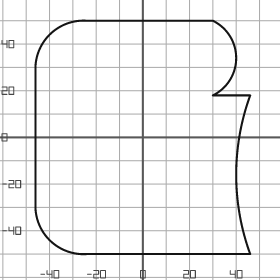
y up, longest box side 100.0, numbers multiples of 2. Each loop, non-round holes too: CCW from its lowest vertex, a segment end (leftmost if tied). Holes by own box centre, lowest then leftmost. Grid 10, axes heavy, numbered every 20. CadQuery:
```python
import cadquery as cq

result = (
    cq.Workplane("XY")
    .moveTo(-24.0, -50.0)
    .lineTo(46.0, -50.0)
    .threePointArc((40.0, -16.0), (46.0, 18.0))
    .lineTo(30.0, 18.0)
    .threePointArc((40.0, 34.0), (30.0, 50.0))
    .lineTo(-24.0, 50.0)
    .threePointArc((-40.0, 44.0), (-46.0, 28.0))
    .lineTo(-46.0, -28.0)
    .threePointArc((-40.0, -44.0), (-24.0, -50.0))
    .close()
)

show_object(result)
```